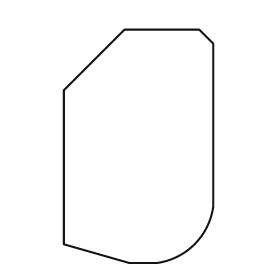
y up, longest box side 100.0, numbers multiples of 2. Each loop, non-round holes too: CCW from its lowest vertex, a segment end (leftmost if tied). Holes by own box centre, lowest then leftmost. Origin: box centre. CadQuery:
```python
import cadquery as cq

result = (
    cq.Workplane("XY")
    .moveTo(-4.0, -50.0)
    .lineTo(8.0, -50.0)
    .threePointArc((24.0, -42.0), (32.0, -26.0))
    .lineTo(32.0, 44.0)
    .lineTo(26.0, 50.0)
    .lineTo(-6.0, 50.0)
    .lineTo(-32.0, 24.0)
    .lineTo(-32.0, -42.0)
    .close()
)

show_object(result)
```